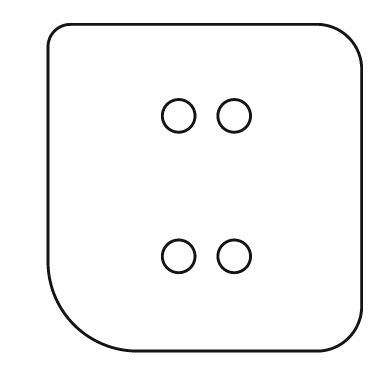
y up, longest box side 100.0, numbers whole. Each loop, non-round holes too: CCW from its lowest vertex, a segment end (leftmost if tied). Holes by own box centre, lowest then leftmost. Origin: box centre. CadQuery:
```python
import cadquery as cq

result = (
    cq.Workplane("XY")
    .moveTo(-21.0, -50.0)
    .lineTo(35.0, -50.0)
    .threePointArc((44.0, -46.0), (48.0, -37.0))
    .lineTo(48.0, 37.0)
    .threePointArc((44.0, 46.0), (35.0, 50.0))
    .lineTo(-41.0, 50.0)
    .threePointArc((-46.0, 48.0), (-48.0, 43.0))
    .lineTo(-48.0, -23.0)
    .threePointArc((-40.0, -42.0), (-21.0, -50.0))
    .close()
    .moveTo(-8.0, -21.0)
    .circle(5.0)
    .moveTo(9.0, -21.0)
    .circle(5.0)
    .moveTo(-8.0, 22.0)
    .circle(5.0)
    .moveTo(9.0, 22.0)
    .circle(5.0)
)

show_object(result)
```